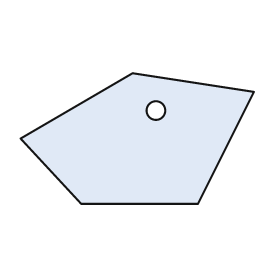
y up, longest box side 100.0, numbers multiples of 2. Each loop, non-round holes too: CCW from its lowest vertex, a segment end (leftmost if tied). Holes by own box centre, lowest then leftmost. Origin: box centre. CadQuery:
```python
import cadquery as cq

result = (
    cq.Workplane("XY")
    .moveTo(-24.0, -28.0)
    .lineTo(26.0, -28.0)
    .lineTo(50.0, 20.0)
    .lineTo(-2.0, 28.0)
    .lineTo(-50.0, 0.0)
    .close()
    .moveTo(8.0, 12.0)
    .circle(4.0)
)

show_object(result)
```